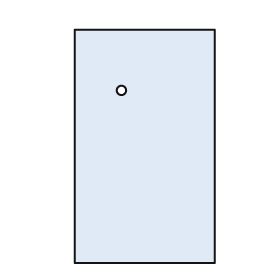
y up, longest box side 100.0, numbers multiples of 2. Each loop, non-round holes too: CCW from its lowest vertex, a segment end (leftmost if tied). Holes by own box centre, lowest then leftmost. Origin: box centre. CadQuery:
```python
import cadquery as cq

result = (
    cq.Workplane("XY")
    .moveTo(-30.0, -50.0)
    .lineTo(30.0, -50.0)
    .lineTo(30.0, 50.0)
    .lineTo(-30.0, 50.0)
    .close()
    .moveTo(-10.0, 24.0)
    .circle(2.0)
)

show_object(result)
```